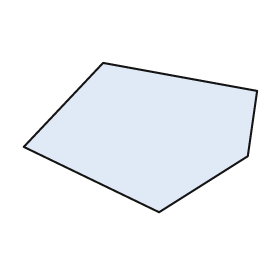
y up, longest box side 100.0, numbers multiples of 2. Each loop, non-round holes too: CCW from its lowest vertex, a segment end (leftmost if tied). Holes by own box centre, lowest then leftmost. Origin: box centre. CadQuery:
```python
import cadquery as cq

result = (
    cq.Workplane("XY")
    .moveTo(8.0, -32.0)
    .lineTo(46.0, -8.0)
    .lineTo(50.0, 20.0)
    .lineTo(-16.0, 32.0)
    .lineTo(-50.0, -4.0)
    .close()
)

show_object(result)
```